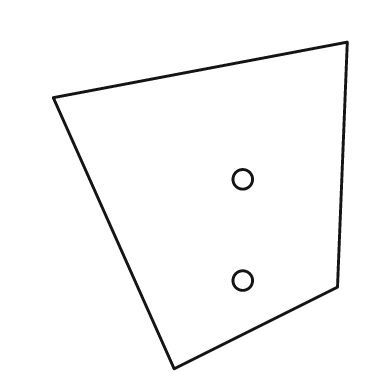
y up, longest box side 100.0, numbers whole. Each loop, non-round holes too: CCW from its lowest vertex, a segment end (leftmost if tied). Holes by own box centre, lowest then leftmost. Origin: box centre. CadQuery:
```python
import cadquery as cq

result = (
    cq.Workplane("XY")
    .moveTo(-8.0, -50.0)
    .lineTo(42.0, -25.0)
    .lineTo(45.0, 50.0)
    .lineTo(-45.0, 33.0)
    .close()
    .moveTo(13.0, -23.0)
    .circle(3.0)
    .moveTo(13.0, 8.0)
    .circle(3.0)
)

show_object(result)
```